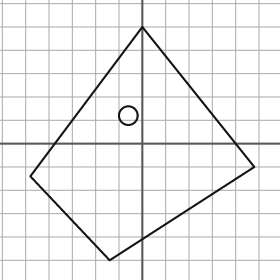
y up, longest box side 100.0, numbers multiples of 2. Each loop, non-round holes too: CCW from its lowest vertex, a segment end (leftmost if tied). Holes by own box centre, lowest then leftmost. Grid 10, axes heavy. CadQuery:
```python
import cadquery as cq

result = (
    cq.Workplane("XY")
    .moveTo(-14.0, -50.0)
    .lineTo(48.0, -10.0)
    .lineTo(0.0, 50.0)
    .lineTo(-48.0, -14.0)
    .close()
    .moveTo(-6.0, 12.0)
    .circle(4.0)
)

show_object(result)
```